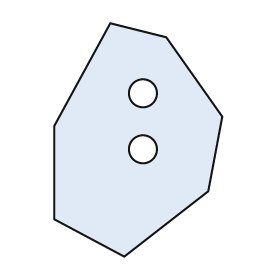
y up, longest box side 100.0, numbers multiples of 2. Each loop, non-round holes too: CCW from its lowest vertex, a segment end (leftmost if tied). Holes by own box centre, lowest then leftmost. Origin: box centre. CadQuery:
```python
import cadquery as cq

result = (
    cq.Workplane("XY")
    .moveTo(-6.0, -50.0)
    .lineTo(30.0, -22.0)
    .lineTo(36.0, 10.0)
    .lineTo(12.0, 44.0)
    .lineTo(-12.0, 50.0)
    .lineTo(-36.0, 6.0)
    .lineTo(-36.0, -34.0)
    .close()
    .moveTo(2.0, -4.0)
    .circle(6.0)
    .moveTo(2.0, 20.0)
    .circle(6.0)
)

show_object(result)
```